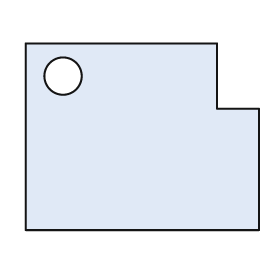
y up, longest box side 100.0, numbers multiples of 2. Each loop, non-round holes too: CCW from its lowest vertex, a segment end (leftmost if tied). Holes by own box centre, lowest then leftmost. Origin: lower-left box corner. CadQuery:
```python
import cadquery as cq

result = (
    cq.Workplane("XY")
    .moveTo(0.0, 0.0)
    .lineTo(100.0, 0.0)
    .lineTo(100.0, 52.0)
    .lineTo(82.0, 52.0)
    .lineTo(82.0, 80.0)
    .lineTo(0.0, 80.0)
    .close()
    .moveTo(16.0, 66.0)
    .circle(8.0)
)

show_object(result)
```